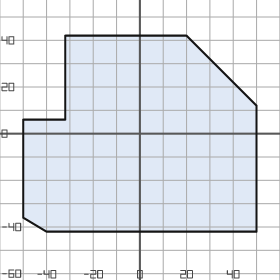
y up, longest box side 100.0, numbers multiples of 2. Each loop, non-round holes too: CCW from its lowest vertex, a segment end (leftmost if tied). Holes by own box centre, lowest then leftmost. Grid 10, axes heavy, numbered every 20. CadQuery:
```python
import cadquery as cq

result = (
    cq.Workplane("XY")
    .moveTo(-40.0, -42.0)
    .lineTo(50.0, -42.0)
    .lineTo(50.0, 12.0)
    .lineTo(20.0, 42.0)
    .lineTo(-32.0, 42.0)
    .lineTo(-32.0, 6.0)
    .lineTo(-50.0, 6.0)
    .lineTo(-50.0, -36.0)
    .close()
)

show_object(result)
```